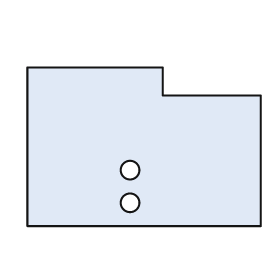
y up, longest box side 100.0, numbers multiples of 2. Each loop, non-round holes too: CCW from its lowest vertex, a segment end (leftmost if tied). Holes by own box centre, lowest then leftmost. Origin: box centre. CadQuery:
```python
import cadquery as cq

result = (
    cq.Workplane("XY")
    .moveTo(-50.0, -34.0)
    .lineTo(50.0, -34.0)
    .lineTo(50.0, 22.0)
    .lineTo(8.0, 22.0)
    .lineTo(8.0, 34.0)
    .lineTo(-50.0, 34.0)
    .close()
    .moveTo(-6.0, -24.0)
    .circle(4.0)
    .moveTo(-6.0, -10.0)
    .circle(4.0)
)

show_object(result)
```